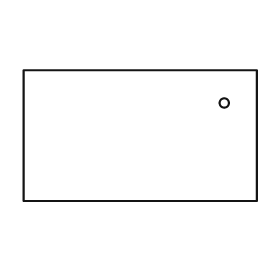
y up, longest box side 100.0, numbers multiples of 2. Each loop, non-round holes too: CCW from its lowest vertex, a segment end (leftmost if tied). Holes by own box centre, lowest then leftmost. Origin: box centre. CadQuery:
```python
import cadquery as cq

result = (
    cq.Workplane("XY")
    .moveTo(-50.0, -28.0)
    .lineTo(50.0, -28.0)
    .lineTo(50.0, 28.0)
    .lineTo(-50.0, 28.0)
    .close()
    .moveTo(36.0, 14.0)
    .circle(2.0)
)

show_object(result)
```